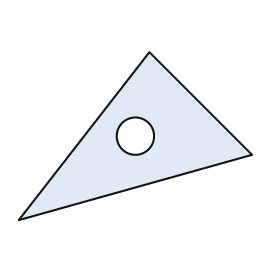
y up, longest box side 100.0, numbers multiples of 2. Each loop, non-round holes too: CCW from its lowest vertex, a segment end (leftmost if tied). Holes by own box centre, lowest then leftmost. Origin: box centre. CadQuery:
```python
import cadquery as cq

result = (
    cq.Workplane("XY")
    .moveTo(-50.0, -36.0)
    .lineTo(50.0, -8.0)
    .lineTo(6.0, 36.0)
    .close()
    .moveTo(0.0, 0.0)
    .circle(8.0)
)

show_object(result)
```